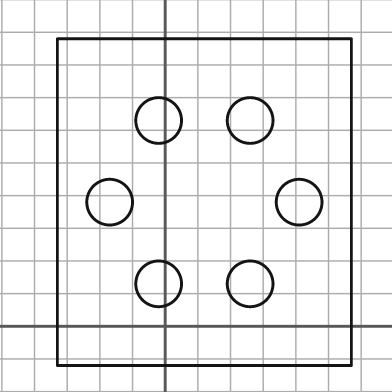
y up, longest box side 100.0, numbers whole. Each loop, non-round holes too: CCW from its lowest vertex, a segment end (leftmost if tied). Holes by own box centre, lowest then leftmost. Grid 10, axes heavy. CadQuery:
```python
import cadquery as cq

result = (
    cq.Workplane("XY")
    .moveTo(-33.0, -12.0)
    .lineTo(57.0, -12.0)
    .lineTo(57.0, 88.0)
    .lineTo(-33.0, 88.0)
    .close()
    .moveTo(-2.0, 13.0)
    .circle(7.0)
    .moveTo(26.0, 13.0)
    .circle(7.0)
    .moveTo(-17.0, 38.0)
    .circle(7.0)
    .moveTo(41.0, 38.0)
    .circle(7.0)
    .moveTo(-2.0, 63.0)
    .circle(7.0)
    .moveTo(26.0, 63.0)
    .circle(7.0)
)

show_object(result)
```